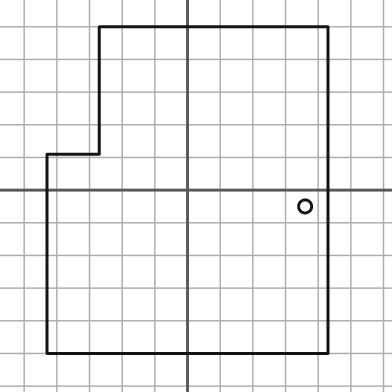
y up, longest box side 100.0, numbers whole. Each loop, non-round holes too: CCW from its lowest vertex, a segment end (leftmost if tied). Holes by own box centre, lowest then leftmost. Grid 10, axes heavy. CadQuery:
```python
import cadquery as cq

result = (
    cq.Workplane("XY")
    .moveTo(-43.0, -50.0)
    .lineTo(43.0, -50.0)
    .lineTo(43.0, 50.0)
    .lineTo(-27.0, 50.0)
    .lineTo(-27.0, 11.0)
    .lineTo(-43.0, 11.0)
    .close()
    .moveTo(36.0, -5.0)
    .circle(2.0)
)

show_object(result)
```